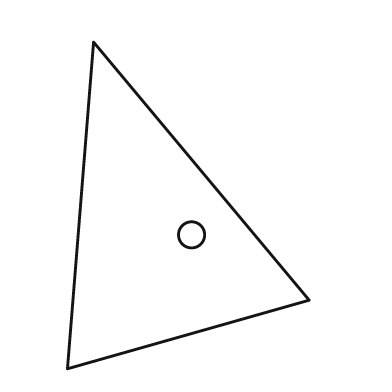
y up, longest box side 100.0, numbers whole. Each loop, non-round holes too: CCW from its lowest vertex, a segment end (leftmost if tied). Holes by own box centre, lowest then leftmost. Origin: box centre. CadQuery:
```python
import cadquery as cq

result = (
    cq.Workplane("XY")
    .moveTo(-37.0, -50.0)
    .lineTo(37.0, -29.0)
    .lineTo(-29.0, 50.0)
    .close()
    .moveTo(1.0, -9.0)
    .circle(4.0)
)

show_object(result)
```